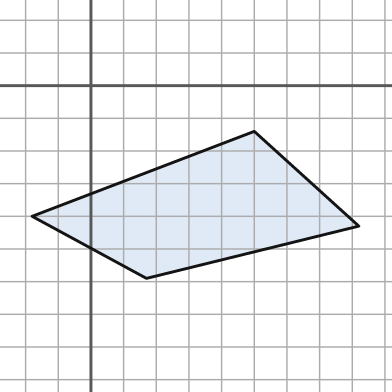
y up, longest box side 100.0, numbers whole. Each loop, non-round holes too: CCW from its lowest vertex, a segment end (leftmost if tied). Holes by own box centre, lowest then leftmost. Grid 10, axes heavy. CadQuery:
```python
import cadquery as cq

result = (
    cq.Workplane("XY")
    .moveTo(17.0, -59.0)
    .lineTo(82.0, -43.0)
    .lineTo(50.0, -14.0)
    .lineTo(-18.0, -40.0)
    .close()
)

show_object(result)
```